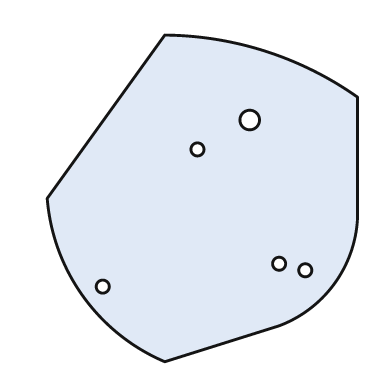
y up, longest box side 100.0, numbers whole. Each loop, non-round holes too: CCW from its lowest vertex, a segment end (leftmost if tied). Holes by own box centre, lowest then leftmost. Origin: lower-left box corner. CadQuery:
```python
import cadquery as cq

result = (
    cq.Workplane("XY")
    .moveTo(36.0, 0.0)
    .lineTo(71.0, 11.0)
    .threePointArc((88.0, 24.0), (95.0, 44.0))
    .lineTo(95.0, 81.0)
    .threePointArc((67.0, 95.0), (36.0, 100.0))
    .lineTo(0.0, 50.0)
    .threePointArc((11.0, 20.0), (36.0, 0.0))
    .close()
    .moveTo(17.0, 23.0)
    .circle(2.0)
    .moveTo(79.0, 28.0)
    .circle(2.0)
    .moveTo(71.0, 30.0)
    .circle(2.0)
    .moveTo(46.0, 65.0)
    .circle(2.0)
    .moveTo(62.0, 74.0)
    .circle(3.0)
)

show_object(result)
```